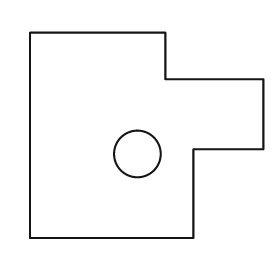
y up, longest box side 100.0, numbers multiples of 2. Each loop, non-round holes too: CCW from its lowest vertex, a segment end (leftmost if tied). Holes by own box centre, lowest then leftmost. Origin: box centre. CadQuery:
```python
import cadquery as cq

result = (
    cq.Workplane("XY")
    .moveTo(-50.0, -44.0)
    .lineTo(20.0, -44.0)
    .lineTo(20.0, -6.0)
    .lineTo(50.0, -6.0)
    .lineTo(50.0, 24.0)
    .lineTo(8.0, 24.0)
    .lineTo(8.0, 44.0)
    .lineTo(-50.0, 44.0)
    .close()
    .moveTo(-4.0, -8.0)
    .circle(10.0)
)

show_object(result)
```